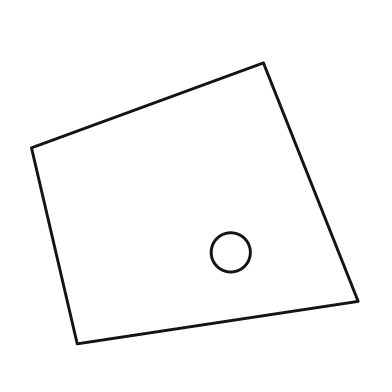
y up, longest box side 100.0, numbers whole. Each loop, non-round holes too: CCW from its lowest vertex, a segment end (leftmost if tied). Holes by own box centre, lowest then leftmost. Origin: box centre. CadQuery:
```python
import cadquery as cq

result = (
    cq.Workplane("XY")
    .moveTo(-36.0, -43.0)
    .lineTo(50.0, -30.0)
    .lineTo(21.0, 43.0)
    .lineTo(-50.0, 17.0)
    .close()
    .moveTo(11.0, -15.0)
    .circle(6.0)
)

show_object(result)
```